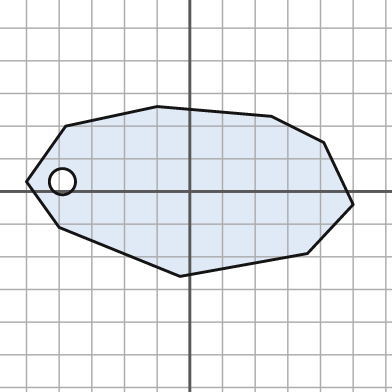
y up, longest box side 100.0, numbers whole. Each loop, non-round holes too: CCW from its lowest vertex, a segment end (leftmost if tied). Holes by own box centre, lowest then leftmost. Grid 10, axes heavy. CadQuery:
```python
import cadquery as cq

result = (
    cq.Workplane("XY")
    .moveTo(-3.0, -26.0)
    .lineTo(36.0, -19.0)
    .lineTo(50.0, -4.0)
    .lineTo(41.0, 15.0)
    .lineTo(25.0, 23.0)
    .lineTo(-10.0, 26.0)
    .lineTo(-38.0, 20.0)
    .lineTo(-50.0, 3.0)
    .lineTo(-40.0, -11.0)
    .close()
    .moveTo(-39.0, 3.0)
    .circle(4.0)
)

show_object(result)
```